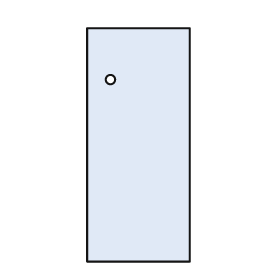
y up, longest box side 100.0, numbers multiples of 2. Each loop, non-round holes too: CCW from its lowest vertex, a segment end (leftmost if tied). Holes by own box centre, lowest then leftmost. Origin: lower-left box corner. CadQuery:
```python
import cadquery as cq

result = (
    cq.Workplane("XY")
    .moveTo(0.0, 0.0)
    .lineTo(44.0, 0.0)
    .lineTo(44.0, 100.0)
    .lineTo(0.0, 100.0)
    .close()
    .moveTo(10.0, 78.0)
    .circle(2.0)
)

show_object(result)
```